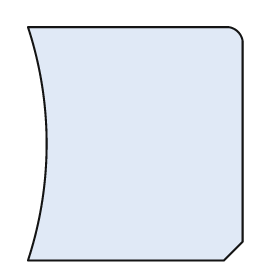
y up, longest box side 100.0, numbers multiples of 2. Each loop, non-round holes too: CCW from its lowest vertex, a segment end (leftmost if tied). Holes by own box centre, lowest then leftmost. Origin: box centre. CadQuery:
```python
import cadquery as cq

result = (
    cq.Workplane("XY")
    .moveTo(-46.0, -50.0)
    .lineTo(38.0, -50.0)
    .lineTo(46.0, -42.0)
    .lineTo(46.0, 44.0)
    .threePointArc((44.0, 48.0), (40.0, 50.0))
    .lineTo(-46.0, 50.0)
    .threePointArc((-38.0, 0.0), (-46.0, -50.0))
    .close()
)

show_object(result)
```